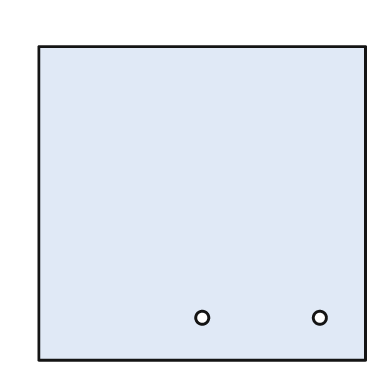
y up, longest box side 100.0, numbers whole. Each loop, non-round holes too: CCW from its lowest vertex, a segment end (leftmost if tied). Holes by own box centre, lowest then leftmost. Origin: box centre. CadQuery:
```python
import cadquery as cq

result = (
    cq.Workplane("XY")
    .moveTo(-50.0, -48.0)
    .lineTo(50.0, -48.0)
    .lineTo(50.0, 48.0)
    .lineTo(-50.0, 48.0)
    .close()
    .moveTo(0.0, -35.0)
    .circle(2.0)
    .moveTo(36.0, -35.0)
    .circle(2.0)
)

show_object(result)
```